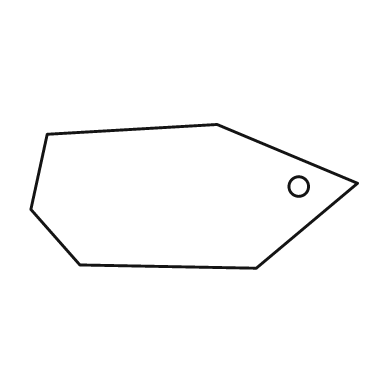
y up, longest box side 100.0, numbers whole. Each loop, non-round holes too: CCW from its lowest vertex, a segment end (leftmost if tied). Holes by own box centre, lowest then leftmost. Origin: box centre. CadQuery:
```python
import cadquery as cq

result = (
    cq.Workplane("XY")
    .moveTo(19.0, -22.0)
    .lineTo(50.0, 4.0)
    .lineTo(7.0, 22.0)
    .lineTo(-45.0, 19.0)
    .lineTo(-50.0, -4.0)
    .lineTo(-35.0, -21.0)
    .close()
    .moveTo(32.0, 3.0)
    .circle(3.0)
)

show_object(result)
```